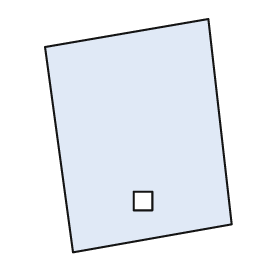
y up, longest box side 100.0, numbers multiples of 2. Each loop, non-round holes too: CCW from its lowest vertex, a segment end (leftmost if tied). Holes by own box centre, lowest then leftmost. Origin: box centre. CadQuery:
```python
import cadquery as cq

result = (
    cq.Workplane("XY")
    .moveTo(-28.0, -50.0)
    .lineTo(40.0, -38.0)
    .lineTo(30.0, 50.0)
    .lineTo(-40.0, 38.0)
    .close()
    .moveTo(-2.0, -32.0)
    .lineTo(6.0, -32.0)
    .lineTo(6.0, -24.0)
    .lineTo(-2.0, -24.0)
    .close()
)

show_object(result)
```